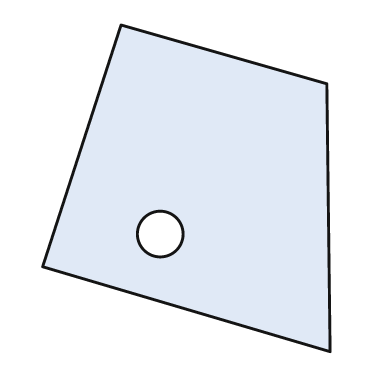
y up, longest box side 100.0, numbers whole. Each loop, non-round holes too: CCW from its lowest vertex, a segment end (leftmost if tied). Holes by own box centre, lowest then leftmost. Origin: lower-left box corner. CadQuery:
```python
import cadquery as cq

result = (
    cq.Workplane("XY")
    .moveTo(88.0, 0.0)
    .lineTo(87.0, 82.0)
    .lineTo(24.0, 100.0)
    .lineTo(0.0, 26.0)
    .close()
    .moveTo(36.0, 36.0)
    .circle(7.0)
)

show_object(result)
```